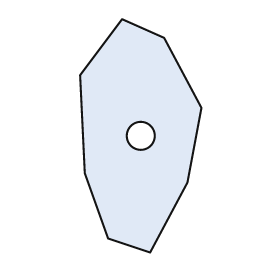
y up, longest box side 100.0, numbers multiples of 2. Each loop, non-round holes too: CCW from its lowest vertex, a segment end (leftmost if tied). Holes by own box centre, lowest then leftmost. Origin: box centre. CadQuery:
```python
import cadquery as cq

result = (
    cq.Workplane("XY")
    .moveTo(4.0, -50.0)
    .lineTo(20.0, -20.0)
    .lineTo(26.0, 12.0)
    .lineTo(10.0, 42.0)
    .lineTo(-8.0, 50.0)
    .lineTo(-26.0, 26.0)
    .lineTo(-24.0, -16.0)
    .lineTo(-14.0, -44.0)
    .close()
    .moveTo(0.0, 0.0)
    .circle(6.0)
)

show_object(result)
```